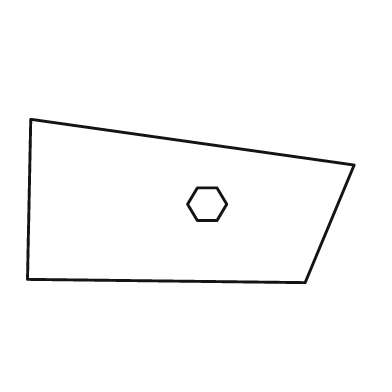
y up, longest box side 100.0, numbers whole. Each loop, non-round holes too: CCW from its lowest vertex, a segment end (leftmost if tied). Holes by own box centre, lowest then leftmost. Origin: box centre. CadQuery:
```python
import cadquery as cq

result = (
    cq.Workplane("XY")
    .moveTo(35.0, -25.0)
    .lineTo(50.0, 11.0)
    .lineTo(-49.0, 25.0)
    .lineTo(-50.0, -24.0)
    .close()
    .moveTo(2.0, -6.0)
    .lineTo(8.0, -6.0)
    .lineTo(11.0, -1.0)
    .lineTo(8.0, 4.0)
    .lineTo(2.0, 4.0)
    .lineTo(-1.0, -1.0)
    .close()
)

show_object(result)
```